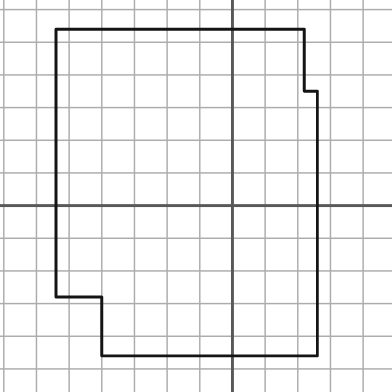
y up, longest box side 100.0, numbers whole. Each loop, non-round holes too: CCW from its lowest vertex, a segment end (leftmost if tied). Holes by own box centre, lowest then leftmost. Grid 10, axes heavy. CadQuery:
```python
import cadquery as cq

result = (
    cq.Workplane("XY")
    .moveTo(-40.0, -46.0)
    .lineTo(26.0, -46.0)
    .lineTo(26.0, 35.0)
    .lineTo(22.0, 35.0)
    .lineTo(22.0, 54.0)
    .lineTo(-54.0, 54.0)
    .lineTo(-54.0, -28.0)
    .lineTo(-40.0, -28.0)
    .close()
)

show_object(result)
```